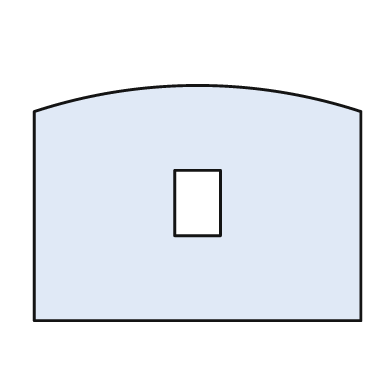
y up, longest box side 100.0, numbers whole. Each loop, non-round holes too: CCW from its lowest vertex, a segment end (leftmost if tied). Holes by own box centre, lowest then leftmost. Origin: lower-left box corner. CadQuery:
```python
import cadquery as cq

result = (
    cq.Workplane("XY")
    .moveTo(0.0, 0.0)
    .lineTo(100.0, 0.0)
    .lineTo(100.0, 64.0)
    .threePointArc((50.0, 72.0), (0.0, 64.0))
    .close()
    .moveTo(43.0, 26.0)
    .lineTo(57.0, 26.0)
    .lineTo(57.0, 46.0)
    .lineTo(43.0, 46.0)
    .close()
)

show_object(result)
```